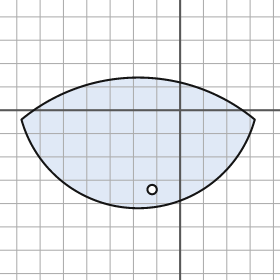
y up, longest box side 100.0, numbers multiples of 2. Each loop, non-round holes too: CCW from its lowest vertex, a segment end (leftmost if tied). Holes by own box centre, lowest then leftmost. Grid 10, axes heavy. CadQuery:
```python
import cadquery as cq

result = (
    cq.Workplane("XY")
    .moveTo(-68.0, -4.0)
    .threePointArc((-18.0, -42.0), (32.0, -4.0))
    .threePointArc((-18.0, 14.0), (-68.0, -4.0))
    .close()
    .moveTo(-12.0, -34.0)
    .circle(2.0)
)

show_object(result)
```